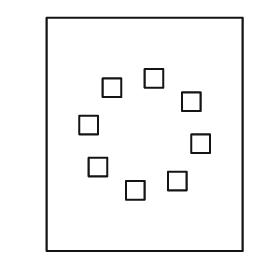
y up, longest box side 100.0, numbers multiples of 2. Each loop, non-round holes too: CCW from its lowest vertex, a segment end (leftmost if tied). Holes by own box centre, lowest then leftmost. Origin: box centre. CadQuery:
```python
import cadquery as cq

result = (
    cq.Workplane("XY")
    .moveTo(-42.0, -50.0)
    .lineTo(42.0, -50.0)
    .lineTo(42.0, 50.0)
    .lineTo(-42.0, 50.0)
    .close()
    .moveTo(-8.0, -28.0)
    .lineTo(0.0, -28.0)
    .lineTo(0.0, -20.0)
    .lineTo(-8.0, -20.0)
    .close()
    .moveTo(10.0, -24.0)
    .lineTo(18.0, -24.0)
    .lineTo(18.0, -16.0)
    .lineTo(10.0, -16.0)
    .close()
    .moveTo(-24.0, -18.0)
    .lineTo(-16.0, -18.0)
    .lineTo(-16.0, -10.0)
    .lineTo(-24.0, -10.0)
    .close()
    .moveTo(20.0, -8.0)
    .lineTo(28.0, -8.0)
    .lineTo(28.0, 0.0)
    .lineTo(20.0, 0.0)
    .close()
    .moveTo(-28.0, 0.0)
    .lineTo(-20.0, 0.0)
    .lineTo(-20.0, 8.0)
    .lineTo(-28.0, 8.0)
    .close()
    .moveTo(16.0, 10.0)
    .lineTo(24.0, 10.0)
    .lineTo(24.0, 18.0)
    .lineTo(16.0, 18.0)
    .close()
    .moveTo(-18.0, 16.0)
    .lineTo(-10.0, 16.0)
    .lineTo(-10.0, 24.0)
    .lineTo(-18.0, 24.0)
    .close()
    .moveTo(0.0, 20.0)
    .lineTo(8.0, 20.0)
    .lineTo(8.0, 28.0)
    .lineTo(0.0, 28.0)
    .close()
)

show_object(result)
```